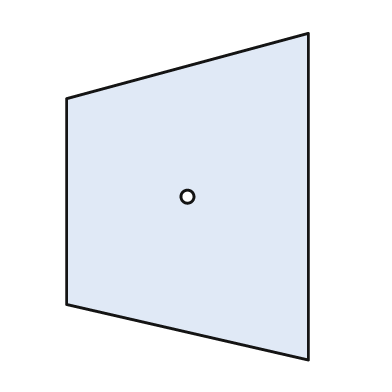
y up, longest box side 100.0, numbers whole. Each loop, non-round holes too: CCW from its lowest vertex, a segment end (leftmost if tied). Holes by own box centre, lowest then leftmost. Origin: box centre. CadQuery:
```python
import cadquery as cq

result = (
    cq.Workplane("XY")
    .moveTo(37.0, -50.0)
    .lineTo(37.0, 50.0)
    .lineTo(-37.0, 30.0)
    .lineTo(-37.0, -33.0)
    .close()
    .moveTo(0.0, 0.0)
    .circle(2.0)
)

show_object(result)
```